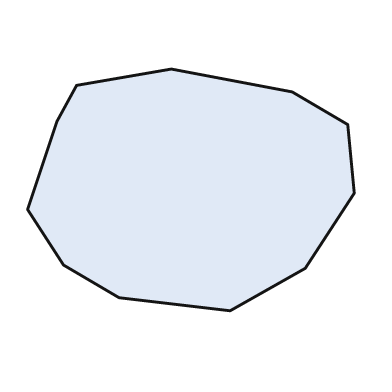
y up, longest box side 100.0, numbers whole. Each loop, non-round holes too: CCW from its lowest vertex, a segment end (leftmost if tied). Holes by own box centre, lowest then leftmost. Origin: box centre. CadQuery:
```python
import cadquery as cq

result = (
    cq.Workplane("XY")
    .moveTo(12.0, -37.0)
    .lineTo(35.0, -24.0)
    .lineTo(50.0, -1.0)
    .lineTo(48.0, 20.0)
    .lineTo(31.0, 30.0)
    .lineTo(-6.0, 37.0)
    .lineTo(-35.0, 32.0)
    .lineTo(-41.0, 21.0)
    .lineTo(-50.0, -6.0)
    .lineTo(-39.0, -23.0)
    .lineTo(-22.0, -33.0)
    .close()
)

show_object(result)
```